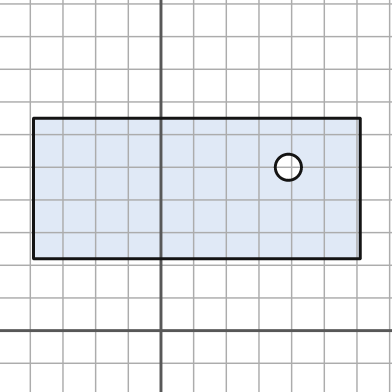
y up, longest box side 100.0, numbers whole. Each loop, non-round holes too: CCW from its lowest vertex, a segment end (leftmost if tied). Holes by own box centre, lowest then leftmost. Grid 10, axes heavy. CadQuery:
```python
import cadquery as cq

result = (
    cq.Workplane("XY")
    .moveTo(-39.0, 22.0)
    .lineTo(61.0, 22.0)
    .lineTo(61.0, 65.0)
    .lineTo(-39.0, 65.0)
    .close()
    .moveTo(39.0, 50.0)
    .circle(4.0)
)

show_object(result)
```